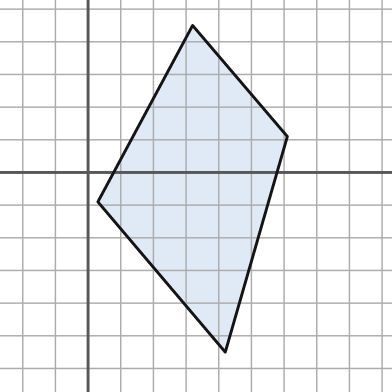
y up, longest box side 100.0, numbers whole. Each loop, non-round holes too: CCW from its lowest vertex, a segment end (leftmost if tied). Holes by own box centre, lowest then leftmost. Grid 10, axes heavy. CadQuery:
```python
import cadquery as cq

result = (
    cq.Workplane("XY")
    .moveTo(42.0, -55.0)
    .lineTo(61.0, 11.0)
    .lineTo(32.0, 45.0)
    .lineTo(3.0, -9.0)
    .close()
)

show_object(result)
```